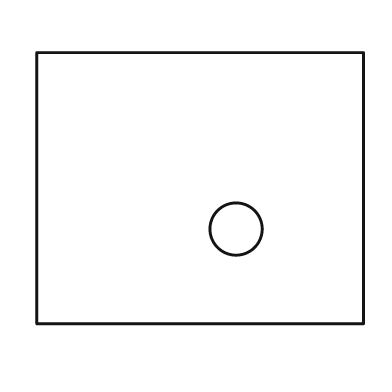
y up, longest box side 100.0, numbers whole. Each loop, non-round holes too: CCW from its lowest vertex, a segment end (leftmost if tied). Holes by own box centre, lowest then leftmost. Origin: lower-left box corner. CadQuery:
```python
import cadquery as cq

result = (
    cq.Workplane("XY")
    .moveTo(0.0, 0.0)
    .lineTo(100.0, 0.0)
    .lineTo(100.0, 83.0)
    .lineTo(0.0, 83.0)
    .close()
    .moveTo(61.0, 29.0)
    .circle(8.0)
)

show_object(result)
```